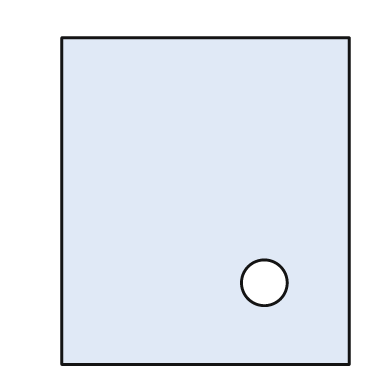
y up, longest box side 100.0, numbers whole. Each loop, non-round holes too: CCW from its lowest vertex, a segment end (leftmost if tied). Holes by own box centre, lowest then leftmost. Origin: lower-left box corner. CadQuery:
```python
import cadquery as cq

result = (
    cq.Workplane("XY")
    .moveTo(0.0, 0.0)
    .lineTo(88.0, 0.0)
    .lineTo(88.0, 100.0)
    .lineTo(0.0, 100.0)
    .close()
    .moveTo(62.0, 25.0)
    .circle(7.0)
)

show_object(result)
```